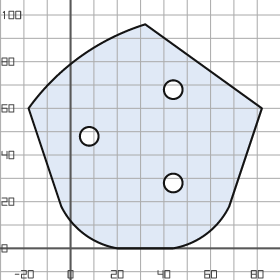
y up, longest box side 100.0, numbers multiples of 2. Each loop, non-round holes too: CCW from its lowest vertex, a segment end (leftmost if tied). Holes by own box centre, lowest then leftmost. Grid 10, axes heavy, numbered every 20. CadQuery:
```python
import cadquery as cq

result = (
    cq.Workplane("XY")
    .moveTo(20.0, 0.0)
    .lineTo(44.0, 0.0)
    .threePointArc((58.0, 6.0), (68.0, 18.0))
    .lineTo(82.0, 60.0)
    .lineTo(32.0, 96.0)
    .threePointArc((4.0, 82.0), (-18.0, 60.0))
    .lineTo(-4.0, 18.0)
    .threePointArc((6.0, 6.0), (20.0, 0.0))
    .close()
    .moveTo(44.0, 28.0)
    .circle(4.0)
    .moveTo(8.0, 48.0)
    .circle(4.0)
    .moveTo(44.0, 68.0)
    .circle(4.0)
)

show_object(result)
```